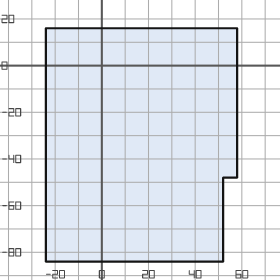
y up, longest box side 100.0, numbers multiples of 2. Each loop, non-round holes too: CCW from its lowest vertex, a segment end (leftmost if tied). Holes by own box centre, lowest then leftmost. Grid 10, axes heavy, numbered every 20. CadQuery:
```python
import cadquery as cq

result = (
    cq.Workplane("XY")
    .moveTo(-24.0, -84.0)
    .lineTo(52.0, -84.0)
    .lineTo(52.0, -48.0)
    .lineTo(58.0, -48.0)
    .lineTo(58.0, 16.0)
    .lineTo(-24.0, 16.0)
    .close()
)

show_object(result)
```